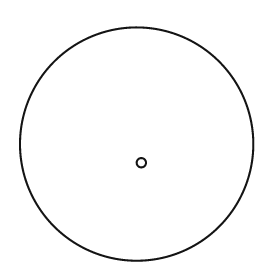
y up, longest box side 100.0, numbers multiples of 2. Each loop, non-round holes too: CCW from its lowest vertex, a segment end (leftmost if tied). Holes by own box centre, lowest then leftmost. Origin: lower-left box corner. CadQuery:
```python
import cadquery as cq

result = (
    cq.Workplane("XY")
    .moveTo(50.0, 50.0)
    .circle(50.0)
    .moveTo(52.0, 42.0)
    .circle(2.0)
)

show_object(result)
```